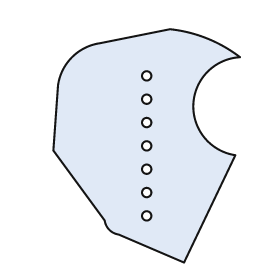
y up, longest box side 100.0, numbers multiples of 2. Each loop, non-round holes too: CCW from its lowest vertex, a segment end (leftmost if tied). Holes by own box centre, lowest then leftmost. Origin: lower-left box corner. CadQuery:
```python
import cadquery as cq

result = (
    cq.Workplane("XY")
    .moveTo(56.0, 0.0)
    .lineTo(78.0, 46.0)
    .threePointArc((60.0, 68.0), (80.0, 88.0))
    .threePointArc((66.0, 96.0), (50.0, 100.0))
    .lineTo(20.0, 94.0)
    .threePointArc((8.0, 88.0), (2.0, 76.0))
    .lineTo(0.0, 48.0)
    .lineTo(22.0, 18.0)
    .threePointArc((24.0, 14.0), (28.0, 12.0))
    .close()
    .moveTo(40.0, 20.0)
    .circle(2.0)
    .moveTo(40.0, 30.0)
    .circle(2.0)
    .moveTo(40.0, 40.0)
    .circle(2.0)
    .moveTo(40.0, 50.0)
    .circle(2.0)
    .moveTo(40.0, 60.0)
    .circle(2.0)
    .moveTo(40.0, 70.0)
    .circle(2.0)
    .moveTo(40.0, 80.0)
    .circle(2.0)
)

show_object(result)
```